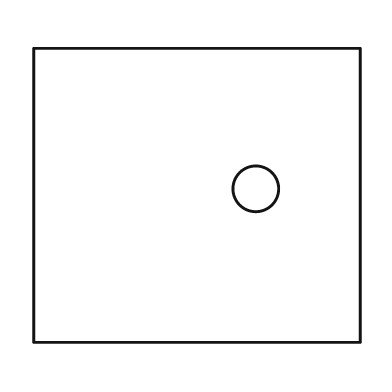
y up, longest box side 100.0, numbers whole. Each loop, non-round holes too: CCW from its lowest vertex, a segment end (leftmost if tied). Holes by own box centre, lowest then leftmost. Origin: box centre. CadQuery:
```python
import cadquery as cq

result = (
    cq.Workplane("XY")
    .moveTo(-50.0, -45.0)
    .lineTo(50.0, -45.0)
    .lineTo(50.0, 45.0)
    .lineTo(-50.0, 45.0)
    .close()
    .moveTo(18.0, 2.0)
    .circle(7.0)
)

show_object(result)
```